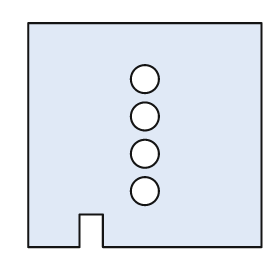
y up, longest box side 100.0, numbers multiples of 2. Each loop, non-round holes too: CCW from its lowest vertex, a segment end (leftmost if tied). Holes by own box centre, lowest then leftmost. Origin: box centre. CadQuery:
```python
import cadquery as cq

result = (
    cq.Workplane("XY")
    .moveTo(-50.0, -48.0)
    .lineTo(-28.0, -48.0)
    .lineTo(-28.0, -34.0)
    .lineTo(-18.0, -34.0)
    .lineTo(-18.0, -48.0)
    .lineTo(50.0, -48.0)
    .lineTo(50.0, 48.0)
    .lineTo(-50.0, 48.0)
    .close()
    .moveTo(0.0, -24.0)
    .circle(6.0)
    .moveTo(0.0, -8.0)
    .circle(6.0)
    .moveTo(0.0, 8.0)
    .circle(6.0)
    .moveTo(0.0, 24.0)
    .circle(6.0)
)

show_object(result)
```